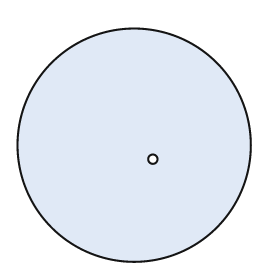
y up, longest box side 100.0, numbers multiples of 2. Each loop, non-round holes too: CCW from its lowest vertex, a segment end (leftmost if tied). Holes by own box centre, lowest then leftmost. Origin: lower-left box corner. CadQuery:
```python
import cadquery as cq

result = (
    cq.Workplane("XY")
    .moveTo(50.0, 50.0)
    .circle(50.0)
    .moveTo(58.0, 44.0)
    .circle(2.0)
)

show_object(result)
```